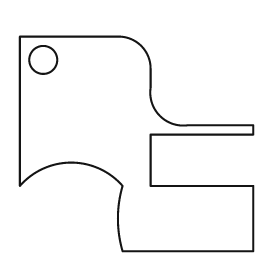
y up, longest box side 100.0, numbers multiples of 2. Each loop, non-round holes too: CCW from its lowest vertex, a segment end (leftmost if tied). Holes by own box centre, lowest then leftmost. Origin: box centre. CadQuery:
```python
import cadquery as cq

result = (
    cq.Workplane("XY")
    .moveTo(-6.0, -46.0)
    .lineTo(50.0, -46.0)
    .lineTo(50.0, -18.0)
    .lineTo(6.0, -18.0)
    .lineTo(6.0, 4.0)
    .lineTo(50.0, 4.0)
    .lineTo(50.0, 8.0)
    .lineTo(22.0, 8.0)
    .threePointArc((10.0, 12.0), (6.0, 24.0))
    .lineTo(6.0, 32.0)
    .threePointArc((2.0, 42.0), (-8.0, 46.0))
    .lineTo(-50.0, 46.0)
    .lineTo(-50.0, -18.0)
    .threePointArc((-28.0, -8.0), (-6.0, -18.0))
    .threePointArc((-8.0, -32.0), (-6.0, -46.0))
    .close()
    .moveTo(-40.0, 36.0)
    .circle(6.0)
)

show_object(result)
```